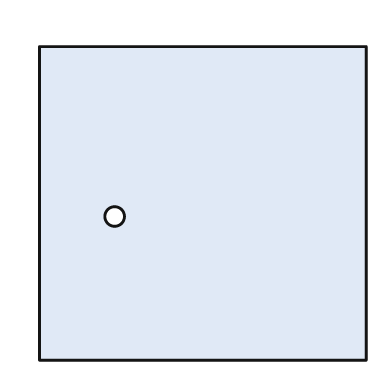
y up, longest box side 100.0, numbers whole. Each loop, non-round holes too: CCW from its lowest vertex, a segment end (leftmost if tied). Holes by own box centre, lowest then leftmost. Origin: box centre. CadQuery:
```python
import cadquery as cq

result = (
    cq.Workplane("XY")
    .moveTo(-50.0, -48.0)
    .lineTo(50.0, -48.0)
    .lineTo(50.0, 48.0)
    .lineTo(-50.0, 48.0)
    .close()
    .moveTo(-27.0, -4.0)
    .circle(3.0)
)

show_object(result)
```